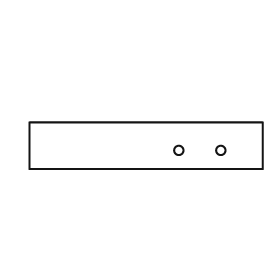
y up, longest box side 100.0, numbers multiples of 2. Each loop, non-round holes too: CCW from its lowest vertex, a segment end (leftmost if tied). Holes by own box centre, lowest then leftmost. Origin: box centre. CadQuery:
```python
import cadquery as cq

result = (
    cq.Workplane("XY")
    .moveTo(-50.0, -10.0)
    .lineTo(50.0, -10.0)
    .lineTo(50.0, 10.0)
    .lineTo(-50.0, 10.0)
    .close()
    .moveTo(14.0, -2.0)
    .circle(2.0)
    .moveTo(32.0, -2.0)
    .circle(2.0)
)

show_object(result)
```